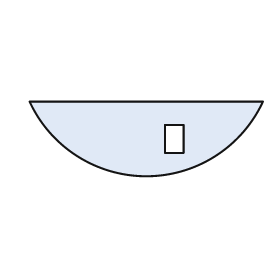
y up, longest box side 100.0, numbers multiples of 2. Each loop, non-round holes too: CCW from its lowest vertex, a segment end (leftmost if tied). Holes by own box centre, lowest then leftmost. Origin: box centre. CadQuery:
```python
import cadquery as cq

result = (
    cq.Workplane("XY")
    .moveTo(-50.0, 16.0)
    .threePointArc((0.0, -16.0), (50.0, 16.0))
    .close()
    .moveTo(8.0, -6.0)
    .lineTo(16.0, -6.0)
    .lineTo(16.0, 6.0)
    .lineTo(8.0, 6.0)
    .close()
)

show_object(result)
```